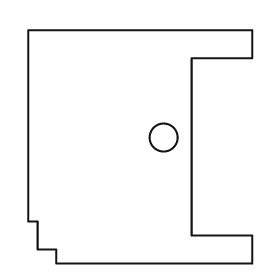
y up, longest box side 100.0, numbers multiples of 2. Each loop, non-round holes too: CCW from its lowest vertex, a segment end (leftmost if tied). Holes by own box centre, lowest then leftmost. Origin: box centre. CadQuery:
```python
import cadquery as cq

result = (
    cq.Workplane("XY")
    .moveTo(-36.0, -50.0)
    .lineTo(48.0, -50.0)
    .lineTo(48.0, -38.0)
    .lineTo(22.0, -38.0)
    .lineTo(22.0, 38.0)
    .lineTo(48.0, 38.0)
    .lineTo(48.0, 50.0)
    .lineTo(-48.0, 50.0)
    .lineTo(-48.0, -32.0)
    .lineTo(-44.0, -32.0)
    .lineTo(-44.0, -44.0)
    .lineTo(-36.0, -44.0)
    .close()
    .moveTo(10.0, 4.0)
    .circle(6.0)
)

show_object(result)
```